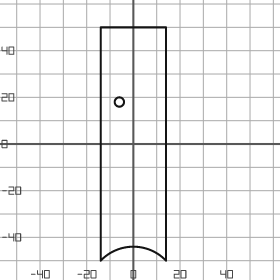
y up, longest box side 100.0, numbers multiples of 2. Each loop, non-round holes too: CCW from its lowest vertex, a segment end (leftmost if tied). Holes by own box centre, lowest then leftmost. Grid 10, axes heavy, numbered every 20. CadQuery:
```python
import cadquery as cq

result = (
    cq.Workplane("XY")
    .moveTo(-14.0, -50.0)
    .threePointArc((0.0, -44.0), (14.0, -50.0))
    .lineTo(14.0, 50.0)
    .lineTo(-14.0, 50.0)
    .close()
    .moveTo(-6.0, 18.0)
    .circle(2.0)
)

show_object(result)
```